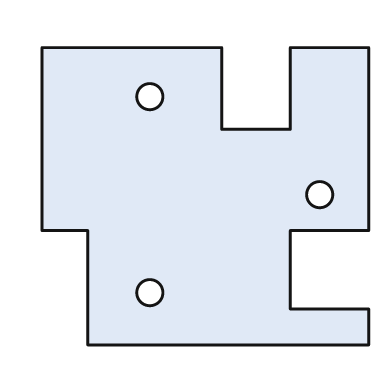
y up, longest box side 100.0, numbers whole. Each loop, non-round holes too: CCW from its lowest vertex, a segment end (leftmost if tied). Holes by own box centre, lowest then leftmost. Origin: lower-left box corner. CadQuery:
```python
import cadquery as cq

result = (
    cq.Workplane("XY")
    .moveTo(14.0, 0.0)
    .lineTo(100.0, 0.0)
    .lineTo(100.0, 11.0)
    .lineTo(76.0, 11.0)
    .lineTo(76.0, 35.0)
    .lineTo(100.0, 35.0)
    .lineTo(100.0, 91.0)
    .lineTo(76.0, 91.0)
    .lineTo(76.0, 66.0)
    .lineTo(55.0, 66.0)
    .lineTo(55.0, 91.0)
    .lineTo(0.0, 91.0)
    .lineTo(0.0, 35.0)
    .lineTo(14.0, 35.0)
    .close()
    .moveTo(33.0, 16.0)
    .circle(4.0)
    .moveTo(85.0, 46.0)
    .circle(4.0)
    .moveTo(33.0, 76.0)
    .circle(4.0)
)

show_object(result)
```